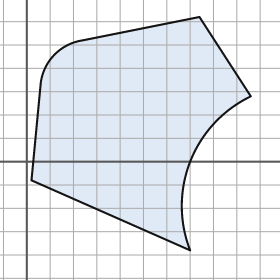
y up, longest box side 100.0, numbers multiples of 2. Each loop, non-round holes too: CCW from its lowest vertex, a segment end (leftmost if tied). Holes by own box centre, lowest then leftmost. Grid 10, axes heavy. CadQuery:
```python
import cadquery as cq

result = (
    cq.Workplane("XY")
    .moveTo(70.0, -38.0)
    .threePointArc((70.0, 0.0), (96.0, 28.0))
    .lineTo(74.0, 62.0)
    .lineTo(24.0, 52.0)
    .threePointArc((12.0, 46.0), (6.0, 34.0))
    .lineTo(2.0, -8.0)
    .close()
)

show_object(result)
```